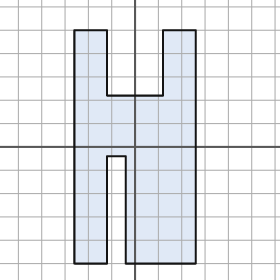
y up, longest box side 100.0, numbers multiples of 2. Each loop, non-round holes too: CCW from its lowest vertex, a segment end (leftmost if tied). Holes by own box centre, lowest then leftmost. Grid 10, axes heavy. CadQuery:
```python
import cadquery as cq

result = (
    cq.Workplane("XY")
    .moveTo(-26.0, -50.0)
    .lineTo(-12.0, -50.0)
    .lineTo(-12.0, -4.0)
    .lineTo(-4.0, -4.0)
    .lineTo(-4.0, -50.0)
    .lineTo(26.0, -50.0)
    .lineTo(26.0, 50.0)
    .lineTo(12.0, 50.0)
    .lineTo(12.0, 22.0)
    .lineTo(-12.0, 22.0)
    .lineTo(-12.0, 50.0)
    .lineTo(-26.0, 50.0)
    .close()
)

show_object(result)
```